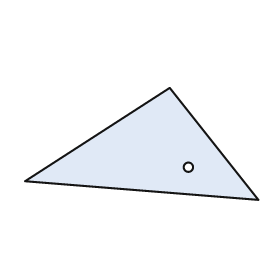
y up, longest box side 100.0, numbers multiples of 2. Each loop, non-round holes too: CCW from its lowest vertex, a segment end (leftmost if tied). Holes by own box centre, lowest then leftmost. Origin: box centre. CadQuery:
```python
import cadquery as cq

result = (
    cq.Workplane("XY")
    .moveTo(50.0, -24.0)
    .lineTo(12.0, 24.0)
    .lineTo(-50.0, -16.0)
    .close()
    .moveTo(20.0, -10.0)
    .circle(2.0)
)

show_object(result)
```